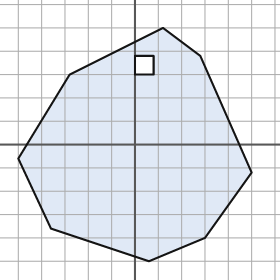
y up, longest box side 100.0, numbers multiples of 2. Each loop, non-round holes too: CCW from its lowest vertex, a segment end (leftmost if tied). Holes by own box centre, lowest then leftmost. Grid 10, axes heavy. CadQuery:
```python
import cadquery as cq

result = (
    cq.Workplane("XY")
    .moveTo(6.0, -50.0)
    .lineTo(30.0, -40.0)
    .lineTo(50.0, -12.0)
    .lineTo(28.0, 38.0)
    .lineTo(12.0, 50.0)
    .lineTo(-28.0, 30.0)
    .lineTo(-50.0, -6.0)
    .lineTo(-36.0, -36.0)
    .close()
    .moveTo(0.0, 30.0)
    .lineTo(8.0, 30.0)
    .lineTo(8.0, 38.0)
    .lineTo(0.0, 38.0)
    .close()
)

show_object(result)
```